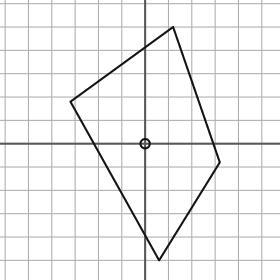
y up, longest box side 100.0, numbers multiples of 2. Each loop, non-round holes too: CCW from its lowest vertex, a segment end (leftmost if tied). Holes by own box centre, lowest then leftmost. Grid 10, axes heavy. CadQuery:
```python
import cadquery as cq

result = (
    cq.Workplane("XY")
    .moveTo(6.0, -50.0)
    .lineTo(32.0, -8.0)
    .lineTo(12.0, 50.0)
    .lineTo(-32.0, 18.0)
    .close()
    .moveTo(0.0, 0.0)
    .circle(2.0)
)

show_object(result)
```